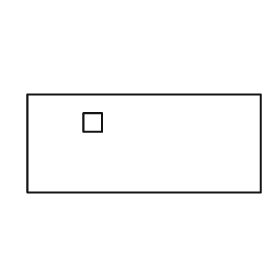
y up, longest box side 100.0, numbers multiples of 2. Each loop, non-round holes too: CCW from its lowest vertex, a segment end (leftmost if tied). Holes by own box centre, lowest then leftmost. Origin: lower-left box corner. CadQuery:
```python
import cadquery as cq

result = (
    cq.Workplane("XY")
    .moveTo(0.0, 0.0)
    .lineTo(100.0, 0.0)
    .lineTo(100.0, 42.0)
    .lineTo(0.0, 42.0)
    .close()
    .moveTo(24.0, 26.0)
    .lineTo(32.0, 26.0)
    .lineTo(32.0, 34.0)
    .lineTo(24.0, 34.0)
    .close()
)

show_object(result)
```